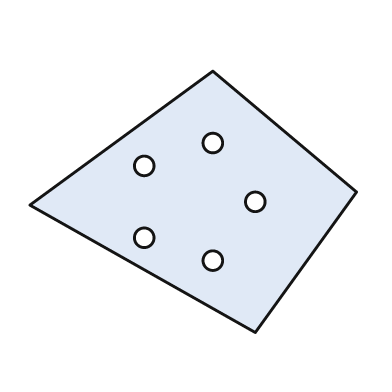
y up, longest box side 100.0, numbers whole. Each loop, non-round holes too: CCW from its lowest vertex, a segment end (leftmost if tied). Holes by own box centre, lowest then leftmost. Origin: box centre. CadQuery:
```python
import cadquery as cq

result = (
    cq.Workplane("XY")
    .moveTo(19.0, -40.0)
    .lineTo(50.0, 3.0)
    .lineTo(6.0, 40.0)
    .lineTo(-50.0, -1.0)
    .close()
    .moveTo(6.0, -18.0)
    .circle(3.0)
    .moveTo(-15.0, -11.0)
    .circle(3.0)
    .moveTo(19.0, 0.0)
    .circle(3.0)
    .moveTo(-15.0, 11.0)
    .circle(3.0)
    .moveTo(6.0, 18.0)
    .circle(3.0)
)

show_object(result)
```